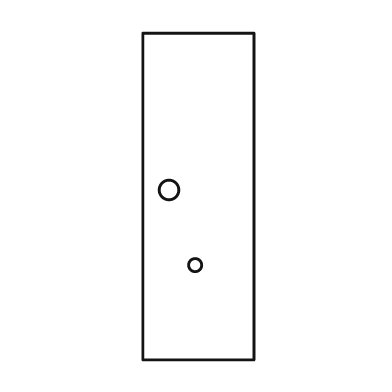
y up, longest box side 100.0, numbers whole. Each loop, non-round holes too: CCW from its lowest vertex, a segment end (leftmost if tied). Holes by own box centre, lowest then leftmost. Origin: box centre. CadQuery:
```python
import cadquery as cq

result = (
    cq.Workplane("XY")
    .moveTo(-17.0, -50.0)
    .lineTo(17.0, -50.0)
    .lineTo(17.0, 50.0)
    .lineTo(-17.0, 50.0)
    .close()
    .moveTo(-1.0, -21.0)
    .circle(2.0)
    .moveTo(-9.0, 2.0)
    .circle(3.0)
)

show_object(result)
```